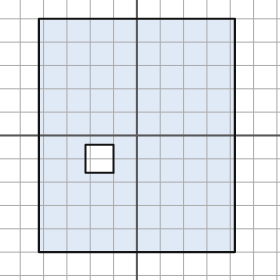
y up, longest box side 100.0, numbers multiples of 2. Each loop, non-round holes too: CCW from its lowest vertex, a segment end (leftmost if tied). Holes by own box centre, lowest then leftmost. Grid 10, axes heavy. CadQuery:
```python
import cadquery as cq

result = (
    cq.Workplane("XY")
    .moveTo(-42.0, -50.0)
    .lineTo(42.0, -50.0)
    .lineTo(42.0, 50.0)
    .lineTo(-42.0, 50.0)
    .close()
    .moveTo(-22.0, -16.0)
    .lineTo(-10.0, -16.0)
    .lineTo(-10.0, -4.0)
    .lineTo(-22.0, -4.0)
    .close()
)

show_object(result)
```